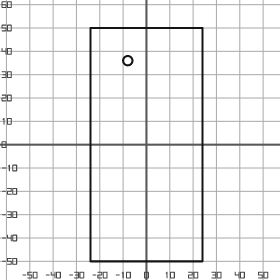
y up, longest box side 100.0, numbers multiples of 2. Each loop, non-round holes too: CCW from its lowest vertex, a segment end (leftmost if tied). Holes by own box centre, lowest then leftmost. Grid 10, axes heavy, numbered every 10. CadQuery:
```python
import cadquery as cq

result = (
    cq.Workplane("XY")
    .moveTo(-24.0, -50.0)
    .lineTo(24.0, -50.0)
    .lineTo(24.0, 50.0)
    .lineTo(-24.0, 50.0)
    .close()
    .moveTo(-8.0, 36.0)
    .circle(2.0)
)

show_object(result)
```